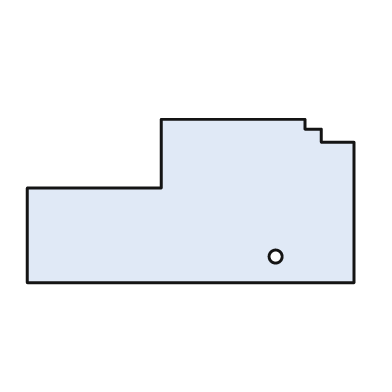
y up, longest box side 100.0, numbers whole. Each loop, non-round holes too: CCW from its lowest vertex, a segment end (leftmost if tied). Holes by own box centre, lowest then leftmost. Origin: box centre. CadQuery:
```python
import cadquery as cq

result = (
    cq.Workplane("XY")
    .moveTo(-50.0, -25.0)
    .lineTo(50.0, -25.0)
    .lineTo(50.0, 18.0)
    .lineTo(40.0, 18.0)
    .lineTo(40.0, 22.0)
    .lineTo(35.0, 22.0)
    .lineTo(35.0, 25.0)
    .lineTo(-9.0, 25.0)
    .lineTo(-9.0, 4.0)
    .lineTo(-50.0, 4.0)
    .close()
    .moveTo(26.0, -17.0)
    .circle(2.0)
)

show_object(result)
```